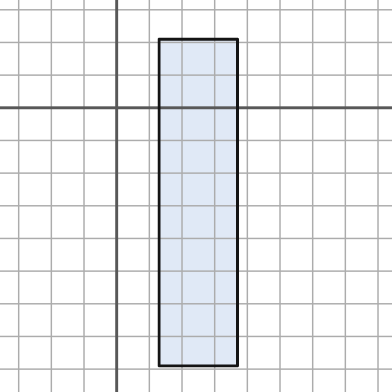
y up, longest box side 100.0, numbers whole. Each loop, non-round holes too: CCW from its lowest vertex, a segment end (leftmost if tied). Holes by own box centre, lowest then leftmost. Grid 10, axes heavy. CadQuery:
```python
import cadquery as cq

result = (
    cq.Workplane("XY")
    .moveTo(13.0, -79.0)
    .lineTo(37.0, -79.0)
    .lineTo(37.0, 21.0)
    .lineTo(13.0, 21.0)
    .close()
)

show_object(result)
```